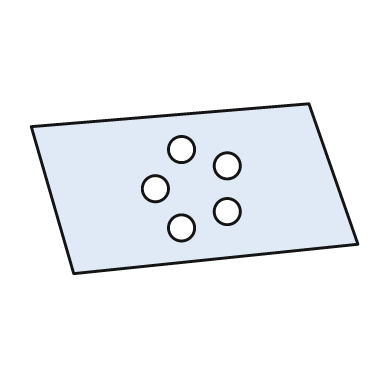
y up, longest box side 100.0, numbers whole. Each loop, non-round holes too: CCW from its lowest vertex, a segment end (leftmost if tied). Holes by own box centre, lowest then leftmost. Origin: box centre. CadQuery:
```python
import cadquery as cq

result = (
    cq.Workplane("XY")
    .moveTo(-37.0, -26.0)
    .lineTo(50.0, -17.0)
    .lineTo(35.0, 26.0)
    .lineTo(-50.0, 19.0)
    .close()
    .moveTo(-4.0, -12.0)
    .circle(4.0)
    .moveTo(10.0, -7.0)
    .circle(4.0)
    .moveTo(-12.0, 0.0)
    .circle(4.0)
    .moveTo(10.0, 7.0)
    .circle(4.0)
    .moveTo(-4.0, 12.0)
    .circle(4.0)
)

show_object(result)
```